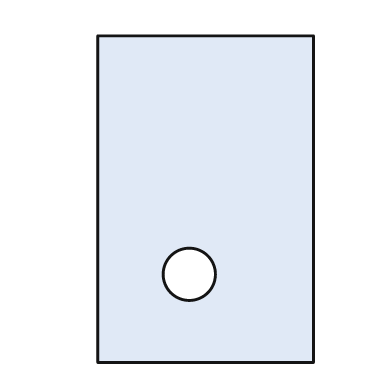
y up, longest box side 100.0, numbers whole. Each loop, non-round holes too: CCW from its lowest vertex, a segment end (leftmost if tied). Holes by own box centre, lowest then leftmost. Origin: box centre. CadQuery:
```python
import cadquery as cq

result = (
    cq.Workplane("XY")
    .moveTo(-33.0, -50.0)
    .lineTo(33.0, -50.0)
    .lineTo(33.0, 50.0)
    .lineTo(-33.0, 50.0)
    .close()
    .moveTo(-5.0, -23.0)
    .circle(8.0)
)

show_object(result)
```